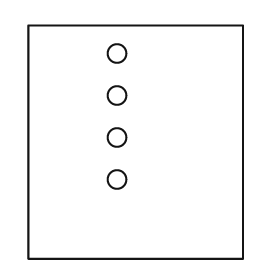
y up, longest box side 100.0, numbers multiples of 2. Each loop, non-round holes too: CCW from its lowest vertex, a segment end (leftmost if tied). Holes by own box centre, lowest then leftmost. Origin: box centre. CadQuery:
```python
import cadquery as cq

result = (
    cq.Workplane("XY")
    .moveTo(-46.0, -50.0)
    .lineTo(46.0, -50.0)
    .lineTo(46.0, 50.0)
    .lineTo(-46.0, 50.0)
    .close()
    .moveTo(-8.0, -16.0)
    .circle(4.0)
    .moveTo(-8.0, 2.0)
    .circle(4.0)
    .moveTo(-8.0, 20.0)
    .circle(4.0)
    .moveTo(-8.0, 38.0)
    .circle(4.0)
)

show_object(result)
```